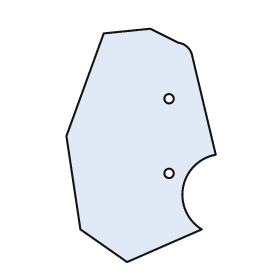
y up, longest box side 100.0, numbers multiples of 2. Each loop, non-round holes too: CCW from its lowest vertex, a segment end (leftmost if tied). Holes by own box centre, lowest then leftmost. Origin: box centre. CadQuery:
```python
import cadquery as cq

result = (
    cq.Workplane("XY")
    .moveTo(-6.0, -50.0)
    .lineTo(26.0, -36.0)
    .threePointArc((18.0, -18.0), (32.0, -4.0))
    .lineTo(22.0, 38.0)
    .threePointArc((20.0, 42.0), (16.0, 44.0))
    .lineTo(4.0, 50.0)
    .lineTo(-16.0, 48.0)
    .lineTo(-32.0, 4.0)
    .lineTo(-26.0, -36.0)
    .close()
    .moveTo(12.0, -12.0)
    .circle(2.0)
    .moveTo(12.0, 20.0)
    .circle(2.0)
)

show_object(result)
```